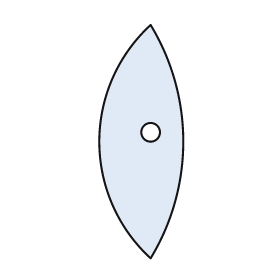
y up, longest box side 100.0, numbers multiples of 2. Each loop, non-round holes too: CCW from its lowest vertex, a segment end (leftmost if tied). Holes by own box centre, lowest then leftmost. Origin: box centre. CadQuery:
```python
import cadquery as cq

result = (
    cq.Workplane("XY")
    .moveTo(4.0, -50.0)
    .threePointArc((18.0, 0.0), (4.0, 50.0))
    .threePointArc((-18.0, 0.0), (4.0, -50.0))
    .close()
    .moveTo(4.0, 4.0)
    .circle(4.0)
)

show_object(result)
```